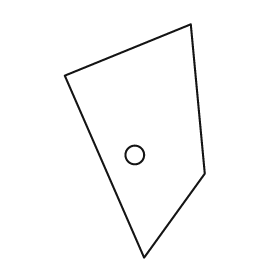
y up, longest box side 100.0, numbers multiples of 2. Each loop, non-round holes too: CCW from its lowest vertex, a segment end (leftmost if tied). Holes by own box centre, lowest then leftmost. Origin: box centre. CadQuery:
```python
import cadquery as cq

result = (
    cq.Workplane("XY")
    .moveTo(4.0, -50.0)
    .lineTo(30.0, -14.0)
    .lineTo(24.0, 50.0)
    .lineTo(-30.0, 28.0)
    .close()
    .moveTo(0.0, -6.0)
    .circle(4.0)
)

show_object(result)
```